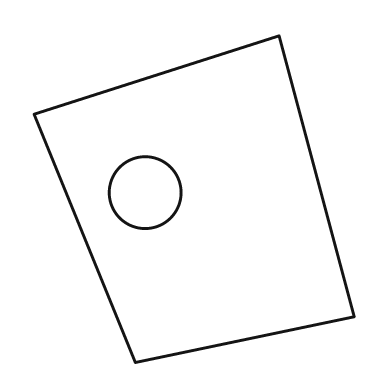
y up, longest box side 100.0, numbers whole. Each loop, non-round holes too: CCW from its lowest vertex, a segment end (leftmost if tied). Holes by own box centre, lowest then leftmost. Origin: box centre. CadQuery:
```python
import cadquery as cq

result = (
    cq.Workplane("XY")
    .moveTo(-18.0, -50.0)
    .lineTo(49.0, -36.0)
    .lineTo(26.0, 50.0)
    .lineTo(-49.0, 26.0)
    .close()
    .moveTo(-15.0, 2.0)
    .circle(11.0)
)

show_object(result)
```